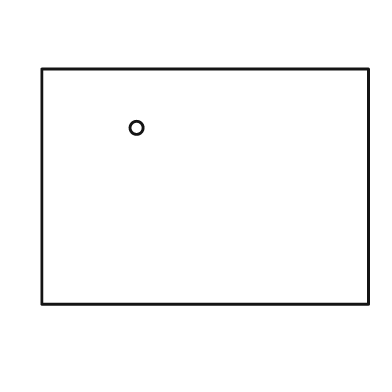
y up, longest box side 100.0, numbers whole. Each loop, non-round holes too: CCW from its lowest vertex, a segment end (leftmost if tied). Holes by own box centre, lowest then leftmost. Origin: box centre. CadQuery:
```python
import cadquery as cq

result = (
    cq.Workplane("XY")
    .moveTo(-50.0, -36.0)
    .lineTo(50.0, -36.0)
    .lineTo(50.0, 36.0)
    .lineTo(-50.0, 36.0)
    .close()
    .moveTo(-21.0, 18.0)
    .circle(2.0)
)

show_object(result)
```